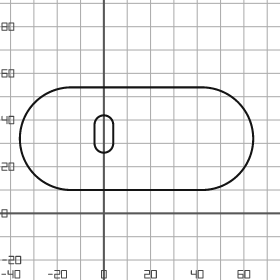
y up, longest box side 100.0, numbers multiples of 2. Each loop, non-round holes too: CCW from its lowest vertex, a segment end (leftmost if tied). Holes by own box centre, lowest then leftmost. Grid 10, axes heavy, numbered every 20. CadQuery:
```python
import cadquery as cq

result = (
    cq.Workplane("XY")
    .moveTo(-14.0, 10.0)
    .lineTo(42.0, 10.0)
    .threePointArc((64.0, 32.0), (42.0, 54.0))
    .lineTo(-14.0, 54.0)
    .threePointArc((-36.0, 32.0), (-14.0, 10.0))
    .close()
    .moveTo(-4.0, 30.0)
    .threePointArc((0.0, 26.0), (4.0, 30.0))
    .lineTo(4.0, 38.0)
    .threePointArc((0.0, 42.0), (-4.0, 38.0))
    .close()
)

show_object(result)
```